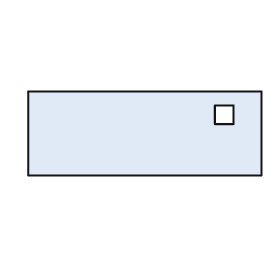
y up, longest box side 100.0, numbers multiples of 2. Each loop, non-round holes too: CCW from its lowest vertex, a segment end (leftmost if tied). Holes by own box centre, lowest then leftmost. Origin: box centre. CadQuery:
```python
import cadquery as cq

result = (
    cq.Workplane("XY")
    .moveTo(-50.0, -18.0)
    .lineTo(50.0, -18.0)
    .lineTo(50.0, 18.0)
    .lineTo(-50.0, 18.0)
    .close()
    .moveTo(30.0, 4.0)
    .lineTo(38.0, 4.0)
    .lineTo(38.0, 12.0)
    .lineTo(30.0, 12.0)
    .close()
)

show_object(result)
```